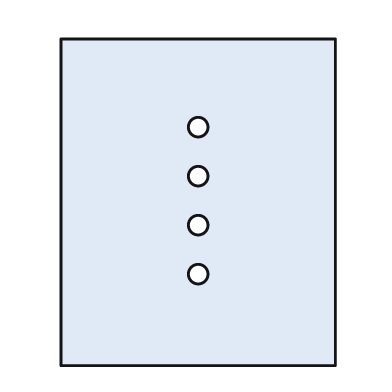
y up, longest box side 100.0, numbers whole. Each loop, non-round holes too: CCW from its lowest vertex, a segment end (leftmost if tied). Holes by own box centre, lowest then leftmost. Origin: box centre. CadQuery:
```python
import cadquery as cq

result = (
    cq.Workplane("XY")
    .moveTo(-42.0, -50.0)
    .lineTo(42.0, -50.0)
    .lineTo(42.0, 50.0)
    .lineTo(-42.0, 50.0)
    .close()
    .moveTo(0.0, -22.0)
    .circle(3.0)
    .moveTo(0.0, -7.0)
    .circle(3.0)
    .moveTo(0.0, 8.0)
    .circle(3.0)
    .moveTo(0.0, 23.0)
    .circle(3.0)
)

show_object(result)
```